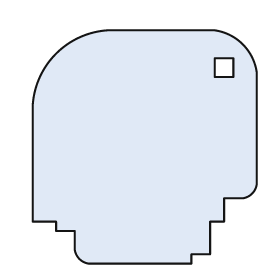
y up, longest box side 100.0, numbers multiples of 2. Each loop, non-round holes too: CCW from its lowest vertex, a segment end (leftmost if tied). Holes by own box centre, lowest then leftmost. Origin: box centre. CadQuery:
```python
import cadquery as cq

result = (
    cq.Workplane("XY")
    .moveTo(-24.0, -50.0)
    .lineTo(20.0, -50.0)
    .lineTo(20.0, -46.0)
    .lineTo(28.0, -46.0)
    .lineTo(28.0, -32.0)
    .lineTo(34.0, -32.0)
    .lineTo(34.0, -22.0)
    .lineTo(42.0, -22.0)
    .threePointArc((46.0, -20.0), (48.0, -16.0))
    .lineTo(48.0, 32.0)
    .threePointArc((42.0, 44.0), (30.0, 50.0))
    .lineTo(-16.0, 50.0)
    .threePointArc((-38.0, 40.0), (-48.0, 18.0))
    .lineTo(-48.0, -32.0)
    .lineTo(-38.0, -32.0)
    .lineTo(-38.0, -36.0)
    .lineTo(-30.0, -36.0)
    .lineTo(-30.0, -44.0)
    .threePointArc((-28.0, -48.0), (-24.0, -50.0))
    .close()
    .moveTo(30.0, 30.0)
    .lineTo(38.0, 30.0)
    .lineTo(38.0, 38.0)
    .lineTo(30.0, 38.0)
    .close()
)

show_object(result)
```